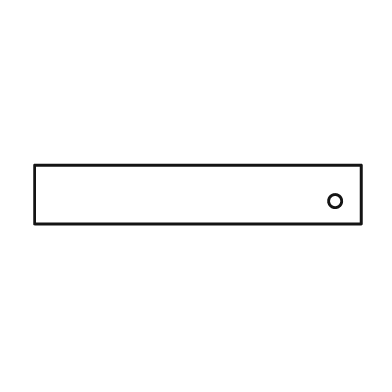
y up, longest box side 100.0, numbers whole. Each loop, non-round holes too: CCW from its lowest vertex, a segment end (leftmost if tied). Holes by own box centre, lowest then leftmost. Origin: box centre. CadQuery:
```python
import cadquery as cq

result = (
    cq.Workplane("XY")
    .moveTo(-50.0, -9.0)
    .lineTo(50.0, -9.0)
    .lineTo(50.0, 9.0)
    .lineTo(-50.0, 9.0)
    .close()
    .moveTo(42.0, -2.0)
    .circle(2.0)
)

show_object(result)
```